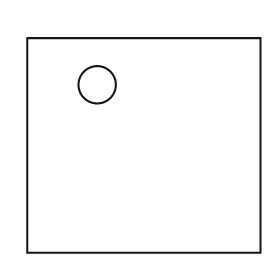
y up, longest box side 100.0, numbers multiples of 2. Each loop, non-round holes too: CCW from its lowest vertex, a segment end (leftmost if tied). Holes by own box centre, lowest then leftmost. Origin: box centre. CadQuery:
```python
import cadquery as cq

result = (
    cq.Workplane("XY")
    .moveTo(-50.0, -46.0)
    .lineTo(50.0, -46.0)
    .lineTo(50.0, 46.0)
    .lineTo(-50.0, 46.0)
    .close()
    .moveTo(-20.0, 26.0)
    .circle(8.0)
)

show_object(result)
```